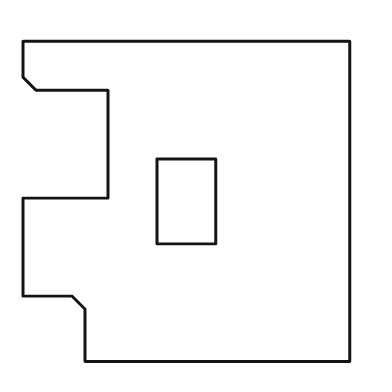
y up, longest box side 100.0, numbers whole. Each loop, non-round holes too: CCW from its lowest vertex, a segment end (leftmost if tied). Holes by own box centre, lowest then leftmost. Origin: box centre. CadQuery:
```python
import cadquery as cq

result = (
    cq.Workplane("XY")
    .moveTo(-31.0, -49.0)
    .lineTo(50.0, -49.0)
    .lineTo(50.0, 49.0)
    .lineTo(-50.0, 49.0)
    .lineTo(-50.0, 38.0)
    .lineTo(-46.0, 34.0)
    .lineTo(-24.0, 34.0)
    .lineTo(-24.0, 1.0)
    .lineTo(-50.0, 1.0)
    .lineTo(-50.0, -29.0)
    .lineTo(-35.0, -29.0)
    .lineTo(-31.0, -33.0)
    .close()
    .moveTo(-9.0, -13.0)
    .lineTo(9.0, -13.0)
    .lineTo(9.0, 13.0)
    .lineTo(-9.0, 13.0)
    .close()
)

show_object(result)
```